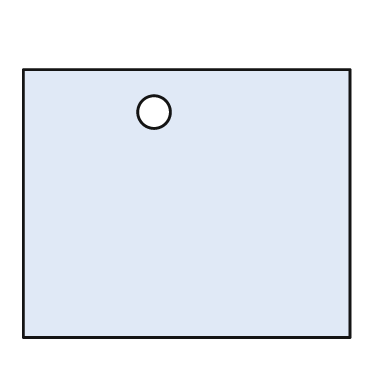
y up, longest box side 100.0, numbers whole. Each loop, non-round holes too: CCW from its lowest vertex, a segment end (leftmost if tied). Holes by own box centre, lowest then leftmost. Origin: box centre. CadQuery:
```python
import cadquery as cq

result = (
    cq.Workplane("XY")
    .moveTo(-50.0, -41.0)
    .lineTo(50.0, -41.0)
    .lineTo(50.0, 41.0)
    .lineTo(-50.0, 41.0)
    .close()
    .moveTo(-10.0, 28.0)
    .circle(5.0)
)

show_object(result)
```